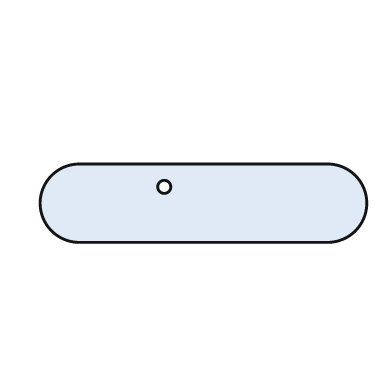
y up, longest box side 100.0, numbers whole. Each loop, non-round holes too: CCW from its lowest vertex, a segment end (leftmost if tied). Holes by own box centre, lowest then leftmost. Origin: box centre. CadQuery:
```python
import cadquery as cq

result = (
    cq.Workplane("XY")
    .moveTo(-38.0, -12.0)
    .lineTo(38.0, -12.0)
    .threePointArc((50.0, 0.0), (38.0, 12.0))
    .lineTo(-38.0, 12.0)
    .threePointArc((-50.0, 0.0), (-38.0, -12.0))
    .close()
    .moveTo(-12.0, 5.0)
    .circle(2.0)
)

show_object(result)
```